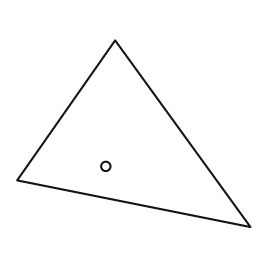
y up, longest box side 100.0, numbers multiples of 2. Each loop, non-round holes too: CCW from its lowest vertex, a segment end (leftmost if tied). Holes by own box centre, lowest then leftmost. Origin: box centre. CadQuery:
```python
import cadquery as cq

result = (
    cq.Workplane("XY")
    .moveTo(50.0, -40.0)
    .lineTo(-8.0, 40.0)
    .lineTo(-50.0, -20.0)
    .close()
    .moveTo(-12.0, -14.0)
    .circle(2.0)
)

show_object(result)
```